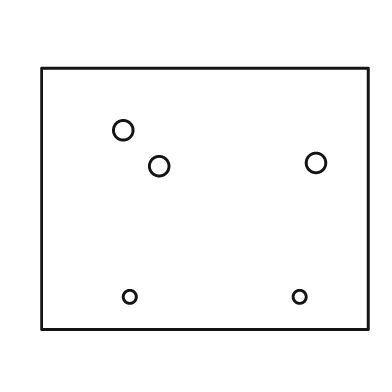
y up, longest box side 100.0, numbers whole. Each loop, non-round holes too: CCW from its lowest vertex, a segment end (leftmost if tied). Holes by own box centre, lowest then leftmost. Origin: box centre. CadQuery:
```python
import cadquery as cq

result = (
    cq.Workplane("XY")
    .moveTo(-50.0, -40.0)
    .lineTo(50.0, -40.0)
    .lineTo(50.0, 40.0)
    .lineTo(-50.0, 40.0)
    .close()
    .moveTo(-23.0, -30.0)
    .circle(2.0)
    .moveTo(29.0, -30.0)
    .circle(2.0)
    .moveTo(-14.0, 10.0)
    .circle(3.0)
    .moveTo(34.0, 11.0)
    .circle(3.0)
    .moveTo(-25.0, 21.0)
    .circle(3.0)
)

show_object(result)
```